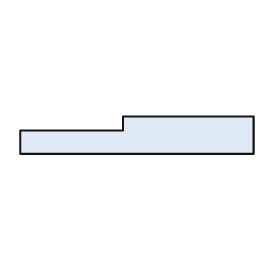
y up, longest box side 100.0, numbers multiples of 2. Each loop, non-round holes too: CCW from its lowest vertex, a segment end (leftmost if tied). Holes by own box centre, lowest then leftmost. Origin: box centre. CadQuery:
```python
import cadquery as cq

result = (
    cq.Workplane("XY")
    .moveTo(-50.0, -8.0)
    .lineTo(50.0, -8.0)
    .lineTo(50.0, 8.0)
    .lineTo(-6.0, 8.0)
    .lineTo(-6.0, 2.0)
    .lineTo(-50.0, 2.0)
    .close()
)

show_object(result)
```